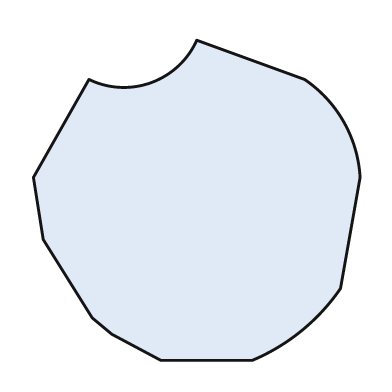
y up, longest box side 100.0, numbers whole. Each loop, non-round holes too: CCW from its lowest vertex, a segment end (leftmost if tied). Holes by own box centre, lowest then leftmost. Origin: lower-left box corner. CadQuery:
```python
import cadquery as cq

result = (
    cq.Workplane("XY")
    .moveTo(39.0, 0.0)
    .lineTo(67.0, 0.0)
    .threePointArc((82.0, 9.0), (94.0, 22.0))
    .lineTo(100.0, 56.0)
    .threePointArc((95.0, 73.0), (83.0, 86.0))
    .lineTo(50.0, 98.0)
    .threePointArc((36.0, 85.0), (17.0, 86.0))
    .lineTo(0.0, 56.0)
    .lineTo(3.0, 37.0)
    .lineTo(18.0, 13.0)
    .lineTo(24.0, 8.0)
    .close()
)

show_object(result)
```